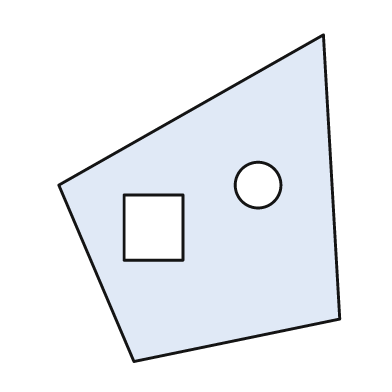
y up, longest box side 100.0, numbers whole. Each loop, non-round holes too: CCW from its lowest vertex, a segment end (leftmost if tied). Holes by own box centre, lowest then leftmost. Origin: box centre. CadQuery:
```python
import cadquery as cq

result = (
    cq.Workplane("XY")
    .moveTo(-20.0, -50.0)
    .lineTo(43.0, -37.0)
    .lineTo(38.0, 50.0)
    .lineTo(-43.0, 4.0)
    .close()
    .moveTo(-23.0, -19.0)
    .lineTo(-5.0, -19.0)
    .lineTo(-5.0, 1.0)
    .lineTo(-23.0, 1.0)
    .close()
    .moveTo(18.0, 4.0)
    .circle(7.0)
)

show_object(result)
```